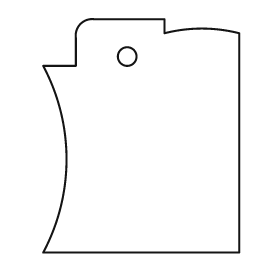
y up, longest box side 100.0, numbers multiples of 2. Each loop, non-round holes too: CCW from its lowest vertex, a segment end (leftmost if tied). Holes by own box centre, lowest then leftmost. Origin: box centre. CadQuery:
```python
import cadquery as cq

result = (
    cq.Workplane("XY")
    .moveTo(-42.0, -50.0)
    .lineTo(42.0, -50.0)
    .lineTo(42.0, 44.0)
    .threePointArc((26.0, 46.0), (10.0, 44.0))
    .lineTo(10.0, 50.0)
    .lineTo(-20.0, 50.0)
    .threePointArc((-26.0, 48.0), (-28.0, 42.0))
    .lineTo(-28.0, 30.0)
    .lineTo(-42.0, 30.0)
    .threePointArc((-32.0, -10.0), (-42.0, -50.0))
    .close()
    .moveTo(-6.0, 34.0)
    .circle(4.0)
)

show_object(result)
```